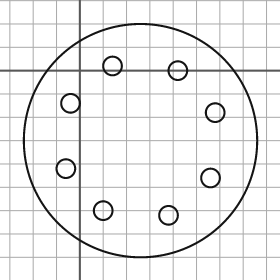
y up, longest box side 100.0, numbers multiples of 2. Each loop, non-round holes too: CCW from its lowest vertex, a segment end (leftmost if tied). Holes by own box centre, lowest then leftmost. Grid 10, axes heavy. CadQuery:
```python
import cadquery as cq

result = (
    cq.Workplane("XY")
    .moveTo(26.0, -30.0)
    .circle(50.0)
    .moveTo(38.0, -62.0)
    .circle(4.0)
    .moveTo(10.0, -60.0)
    .circle(4.0)
    .moveTo(56.0, -46.0)
    .circle(4.0)
    .moveTo(-6.0, -42.0)
    .circle(4.0)
    .moveTo(58.0, -18.0)
    .circle(4.0)
    .moveTo(-4.0, -14.0)
    .circle(4.0)
    .moveTo(42.0, 0.0)
    .circle(4.0)
    .moveTo(14.0, 2.0)
    .circle(4.0)
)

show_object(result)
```